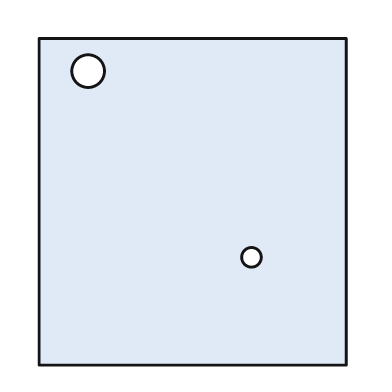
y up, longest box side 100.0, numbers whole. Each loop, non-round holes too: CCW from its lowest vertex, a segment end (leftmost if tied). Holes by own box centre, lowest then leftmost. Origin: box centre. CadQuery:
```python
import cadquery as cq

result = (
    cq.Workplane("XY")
    .moveTo(-47.0, -50.0)
    .lineTo(47.0, -50.0)
    .lineTo(47.0, 50.0)
    .lineTo(-47.0, 50.0)
    .close()
    .moveTo(18.0, -17.0)
    .circle(3.0)
    .moveTo(-32.0, 40.0)
    .circle(5.0)
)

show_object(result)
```